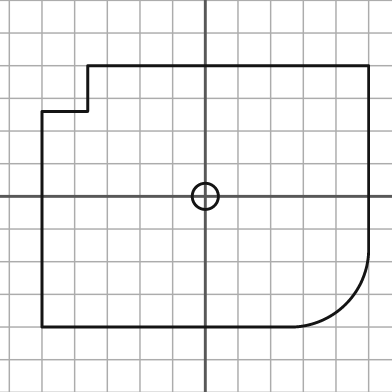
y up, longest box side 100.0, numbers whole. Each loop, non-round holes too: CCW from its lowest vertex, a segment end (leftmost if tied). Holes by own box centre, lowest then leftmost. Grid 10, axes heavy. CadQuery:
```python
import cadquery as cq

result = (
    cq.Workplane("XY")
    .moveTo(-50.0, -40.0)
    .lineTo(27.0, -40.0)
    .threePointArc((43.0, -33.0), (50.0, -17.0))
    .lineTo(50.0, 40.0)
    .lineTo(-36.0, 40.0)
    .lineTo(-36.0, 26.0)
    .lineTo(-50.0, 26.0)
    .close()
    .moveTo(0.0, 0.0)
    .circle(4.0)
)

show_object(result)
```